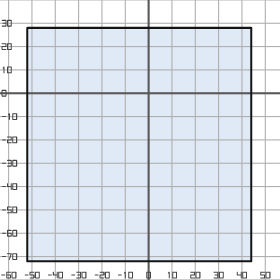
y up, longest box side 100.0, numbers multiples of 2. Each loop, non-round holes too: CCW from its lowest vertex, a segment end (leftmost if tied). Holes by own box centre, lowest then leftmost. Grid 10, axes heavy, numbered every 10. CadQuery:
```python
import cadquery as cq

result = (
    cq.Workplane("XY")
    .moveTo(-52.0, -72.0)
    .lineTo(44.0, -72.0)
    .lineTo(44.0, 28.0)
    .lineTo(-52.0, 28.0)
    .close()
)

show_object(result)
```